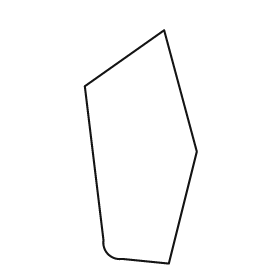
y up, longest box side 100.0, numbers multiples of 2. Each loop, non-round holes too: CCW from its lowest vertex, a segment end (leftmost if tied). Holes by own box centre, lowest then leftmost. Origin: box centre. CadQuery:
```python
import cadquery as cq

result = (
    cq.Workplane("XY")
    .moveTo(12.0, -50.0)
    .lineTo(24.0, -2.0)
    .lineTo(10.0, 50.0)
    .lineTo(-24.0, 26.0)
    .lineTo(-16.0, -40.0)
    .threePointArc((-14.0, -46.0), (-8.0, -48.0))
    .close()
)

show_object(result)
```